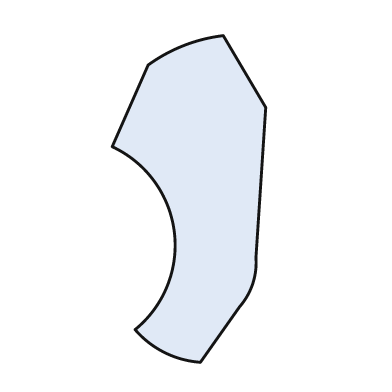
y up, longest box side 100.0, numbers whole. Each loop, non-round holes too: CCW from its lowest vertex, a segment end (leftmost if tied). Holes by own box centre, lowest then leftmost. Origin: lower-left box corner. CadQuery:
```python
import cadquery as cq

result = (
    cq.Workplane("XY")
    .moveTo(27.0, 0.0)
    .lineTo(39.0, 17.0)
    .threePointArc((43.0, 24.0), (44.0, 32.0))
    .lineTo(47.0, 78.0)
    .lineTo(34.0, 100.0)
    .threePointArc((22.0, 97.0), (11.0, 91.0))
    .lineTo(0.0, 66.0)
    .threePointArc((19.0, 40.0), (7.0, 10.0))
    .threePointArc((16.0, 3.0), (27.0, 0.0))
    .close()
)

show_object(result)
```